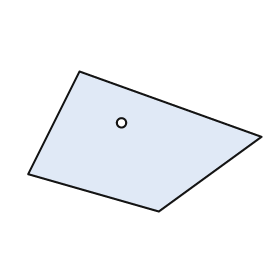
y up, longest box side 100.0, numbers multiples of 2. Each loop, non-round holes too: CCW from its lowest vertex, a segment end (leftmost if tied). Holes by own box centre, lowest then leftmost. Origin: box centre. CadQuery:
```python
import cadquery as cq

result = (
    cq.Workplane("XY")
    .moveTo(6.0, -30.0)
    .lineTo(50.0, 2.0)
    .lineTo(-28.0, 30.0)
    .lineTo(-50.0, -14.0)
    .close()
    .moveTo(-10.0, 8.0)
    .circle(2.0)
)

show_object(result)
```